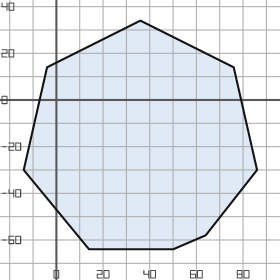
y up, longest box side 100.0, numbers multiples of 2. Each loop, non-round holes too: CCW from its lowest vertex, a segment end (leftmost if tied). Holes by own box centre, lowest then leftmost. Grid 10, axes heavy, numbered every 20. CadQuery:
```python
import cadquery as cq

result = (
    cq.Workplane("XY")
    .moveTo(14.0, -64.0)
    .lineTo(50.0, -64.0)
    .lineTo(64.0, -58.0)
    .lineTo(86.0, -30.0)
    .lineTo(76.0, 14.0)
    .lineTo(36.0, 34.0)
    .lineTo(-4.0, 14.0)
    .lineTo(-14.0, -30.0)
    .close()
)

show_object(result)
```